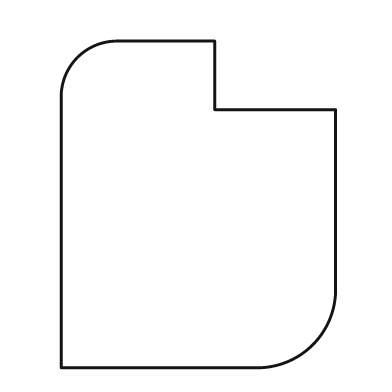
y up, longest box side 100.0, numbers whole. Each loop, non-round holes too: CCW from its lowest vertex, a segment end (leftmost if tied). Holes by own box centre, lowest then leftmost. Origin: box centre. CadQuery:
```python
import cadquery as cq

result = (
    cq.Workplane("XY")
    .moveTo(-42.0, -50.0)
    .lineTo(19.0, -50.0)
    .threePointArc((35.0, -43.0), (42.0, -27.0))
    .lineTo(42.0, 29.0)
    .lineTo(5.0, 29.0)
    .lineTo(5.0, 50.0)
    .lineTo(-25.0, 50.0)
    .threePointArc((-37.0, 45.0), (-42.0, 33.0))
    .close()
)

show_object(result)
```